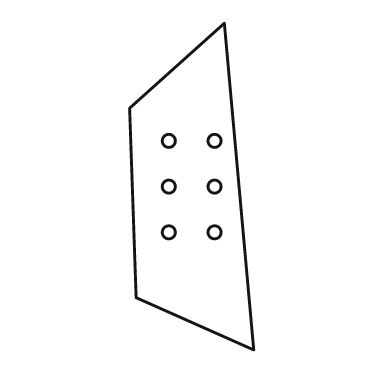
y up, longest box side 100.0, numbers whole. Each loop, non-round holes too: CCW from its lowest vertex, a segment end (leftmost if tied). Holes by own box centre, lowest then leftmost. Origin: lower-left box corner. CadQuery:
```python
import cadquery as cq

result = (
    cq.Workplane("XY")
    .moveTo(38.0, 0.0)
    .lineTo(29.0, 100.0)
    .lineTo(0.0, 74.0)
    .lineTo(2.0, 16.0)
    .close()
    .moveTo(12.0, 36.0)
    .circle(2.0)
    .moveTo(26.0, 36.0)
    .circle(2.0)
    .moveTo(12.0, 50.0)
    .circle(2.0)
    .moveTo(26.0, 50.0)
    .circle(2.0)
    .moveTo(12.0, 64.0)
    .circle(2.0)
    .moveTo(26.0, 64.0)
    .circle(2.0)
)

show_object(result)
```